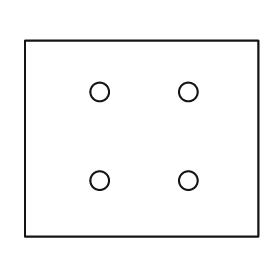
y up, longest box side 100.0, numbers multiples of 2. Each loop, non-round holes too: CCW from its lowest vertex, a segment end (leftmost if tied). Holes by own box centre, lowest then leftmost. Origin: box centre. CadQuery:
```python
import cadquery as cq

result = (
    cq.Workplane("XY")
    .moveTo(-50.0, -42.0)
    .lineTo(50.0, -42.0)
    .lineTo(50.0, 42.0)
    .lineTo(-50.0, 42.0)
    .close()
    .moveTo(-18.0, -18.0)
    .circle(4.0)
    .moveTo(20.0, -18.0)
    .circle(4.0)
    .moveTo(-18.0, 20.0)
    .circle(4.0)
    .moveTo(20.0, 20.0)
    .circle(4.0)
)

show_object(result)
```